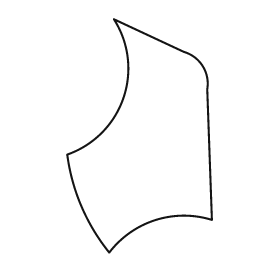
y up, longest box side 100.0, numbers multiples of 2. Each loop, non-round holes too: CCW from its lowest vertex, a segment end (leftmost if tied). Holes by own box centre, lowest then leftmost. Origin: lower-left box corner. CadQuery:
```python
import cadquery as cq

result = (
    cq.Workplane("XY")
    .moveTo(18.0, 0.0)
    .threePointArc((38.0, 14.0), (62.0, 14.0))
    .lineTo(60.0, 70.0)
    .threePointArc((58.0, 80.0), (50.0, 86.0))
    .lineTo(20.0, 100.0)
    .threePointArc((24.0, 66.0), (0.0, 42.0))
    .threePointArc((6.0, 20.0), (18.0, 0.0))
    .close()
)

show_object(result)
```